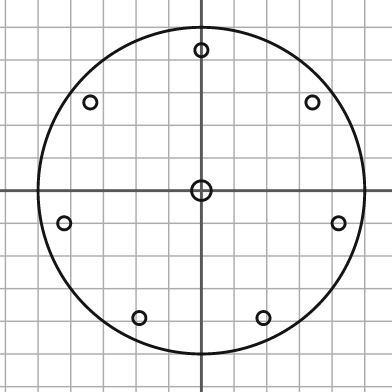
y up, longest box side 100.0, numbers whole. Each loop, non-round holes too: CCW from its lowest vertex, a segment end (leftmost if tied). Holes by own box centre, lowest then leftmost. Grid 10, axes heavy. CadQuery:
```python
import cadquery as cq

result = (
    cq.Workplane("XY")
    .moveTo(0.0, 0.0)
    .circle(50.0)
    .moveTo(-19.0, -39.0)
    .circle(2.0)
    .moveTo(19.0, -39.0)
    .circle(2.0)
    .moveTo(-42.0, -10.0)
    .circle(2.0)
    .moveTo(42.0, -10.0)
    .circle(2.0)
    .moveTo(0.0, 0.0)
    .circle(3.0)
    .moveTo(-34.0, 27.0)
    .circle(2.0)
    .moveTo(34.0, 27.0)
    .circle(2.0)
    .moveTo(0.0, 43.0)
    .circle(2.0)
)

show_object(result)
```